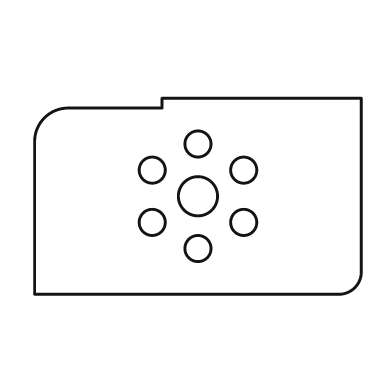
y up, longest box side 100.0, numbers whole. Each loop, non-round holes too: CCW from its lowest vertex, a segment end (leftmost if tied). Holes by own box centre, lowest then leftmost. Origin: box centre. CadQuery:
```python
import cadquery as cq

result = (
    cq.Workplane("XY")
    .moveTo(-50.0, -30.0)
    .lineTo(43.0, -30.0)
    .threePointArc((48.0, -28.0), (50.0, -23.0))
    .lineTo(50.0, 30.0)
    .lineTo(-11.0, 30.0)
    .lineTo(-11.0, 27.0)
    .lineTo(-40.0, 27.0)
    .threePointArc((-47.0, 24.0), (-50.0, 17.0))
    .close()
    .moveTo(0.0, -16.0)
    .circle(4.0)
    .moveTo(-14.0, -8.0)
    .circle(4.0)
    .moveTo(14.0, -8.0)
    .circle(4.0)
    .moveTo(0.0, 0.0)
    .circle(6.0)
    .moveTo(-14.0, 8.0)
    .circle(4.0)
    .moveTo(14.0, 8.0)
    .circle(4.0)
    .moveTo(0.0, 16.0)
    .circle(4.0)
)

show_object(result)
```